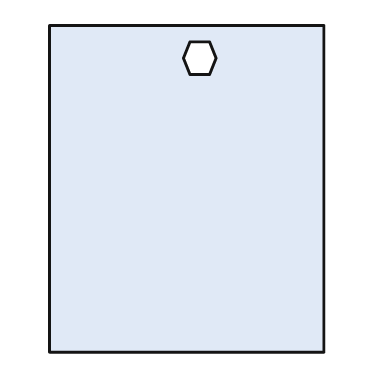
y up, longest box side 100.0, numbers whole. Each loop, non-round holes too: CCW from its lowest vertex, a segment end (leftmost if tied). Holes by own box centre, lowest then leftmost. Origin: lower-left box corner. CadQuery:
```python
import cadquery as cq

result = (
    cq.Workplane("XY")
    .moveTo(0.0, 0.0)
    .lineTo(84.0, 0.0)
    .lineTo(84.0, 100.0)
    .lineTo(0.0, 100.0)
    .close()
    .moveTo(43.0, 85.0)
    .lineTo(49.0, 85.0)
    .lineTo(51.0, 90.0)
    .lineTo(49.0, 95.0)
    .lineTo(43.0, 95.0)
    .lineTo(41.0, 90.0)
    .close()
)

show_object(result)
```